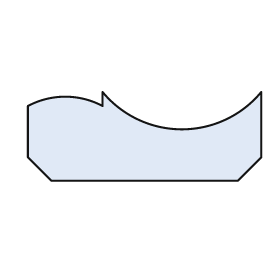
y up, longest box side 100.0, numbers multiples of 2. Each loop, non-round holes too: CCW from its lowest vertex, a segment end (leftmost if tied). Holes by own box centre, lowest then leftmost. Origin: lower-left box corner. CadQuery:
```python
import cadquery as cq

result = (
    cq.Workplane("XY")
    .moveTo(10.0, 0.0)
    .lineTo(90.0, 0.0)
    .lineTo(100.0, 10.0)
    .lineTo(100.0, 38.0)
    .threePointArc((66.0, 22.0), (32.0, 38.0))
    .lineTo(32.0, 32.0)
    .threePointArc((16.0, 36.0), (0.0, 32.0))
    .lineTo(0.0, 10.0)
    .close()
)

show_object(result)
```